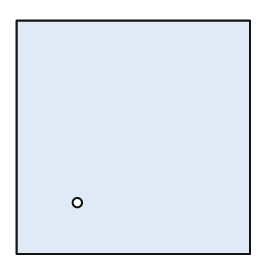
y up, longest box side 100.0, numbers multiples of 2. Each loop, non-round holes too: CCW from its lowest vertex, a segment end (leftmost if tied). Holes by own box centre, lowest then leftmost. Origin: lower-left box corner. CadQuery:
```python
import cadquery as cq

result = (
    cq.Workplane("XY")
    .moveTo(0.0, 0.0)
    .lineTo(100.0, 0.0)
    .lineTo(100.0, 100.0)
    .lineTo(0.0, 100.0)
    .close()
    .moveTo(26.0, 22.0)
    .circle(2.0)
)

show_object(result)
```